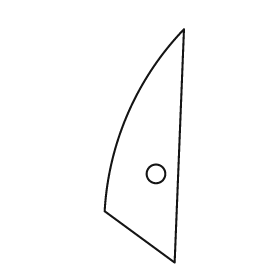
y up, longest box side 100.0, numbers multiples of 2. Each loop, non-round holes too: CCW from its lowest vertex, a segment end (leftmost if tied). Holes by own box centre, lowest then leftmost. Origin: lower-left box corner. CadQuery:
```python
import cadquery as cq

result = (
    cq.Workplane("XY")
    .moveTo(30.0, 0.0)
    .lineTo(34.0, 100.0)
    .threePointArc((10.0, 64.0), (0.0, 22.0))
    .close()
    .moveTo(22.0, 38.0)
    .circle(4.0)
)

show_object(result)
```